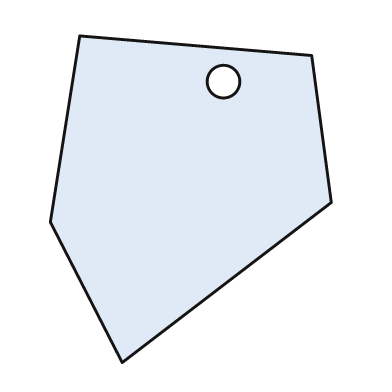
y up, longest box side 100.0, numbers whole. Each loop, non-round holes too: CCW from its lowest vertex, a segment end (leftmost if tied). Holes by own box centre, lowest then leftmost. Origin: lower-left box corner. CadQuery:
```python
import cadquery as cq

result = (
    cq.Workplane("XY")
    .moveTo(22.0, 0.0)
    .lineTo(86.0, 49.0)
    .lineTo(80.0, 94.0)
    .lineTo(9.0, 100.0)
    .lineTo(0.0, 43.0)
    .close()
    .moveTo(53.0, 86.0)
    .circle(5.0)
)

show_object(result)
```